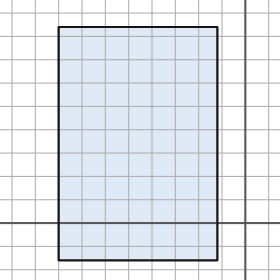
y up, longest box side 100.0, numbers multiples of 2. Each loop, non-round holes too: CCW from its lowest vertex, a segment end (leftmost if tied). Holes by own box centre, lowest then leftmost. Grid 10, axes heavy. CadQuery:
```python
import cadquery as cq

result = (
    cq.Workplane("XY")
    .moveTo(-80.0, -16.0)
    .lineTo(-12.0, -16.0)
    .lineTo(-12.0, 84.0)
    .lineTo(-80.0, 84.0)
    .close()
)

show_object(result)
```